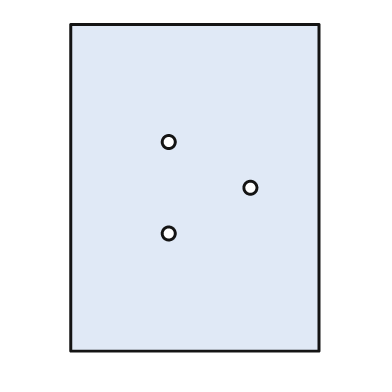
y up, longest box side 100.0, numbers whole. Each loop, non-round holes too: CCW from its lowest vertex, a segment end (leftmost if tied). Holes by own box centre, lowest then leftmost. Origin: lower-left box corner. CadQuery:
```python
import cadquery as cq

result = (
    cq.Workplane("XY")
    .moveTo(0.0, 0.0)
    .lineTo(76.0, 0.0)
    .lineTo(76.0, 100.0)
    .lineTo(0.0, 100.0)
    .close()
    .moveTo(30.0, 36.0)
    .circle(2.0)
    .moveTo(55.0, 50.0)
    .circle(2.0)
    .moveTo(30.0, 64.0)
    .circle(2.0)
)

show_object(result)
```